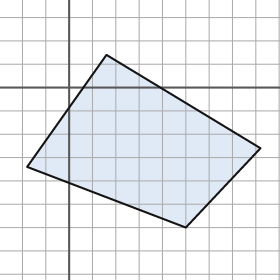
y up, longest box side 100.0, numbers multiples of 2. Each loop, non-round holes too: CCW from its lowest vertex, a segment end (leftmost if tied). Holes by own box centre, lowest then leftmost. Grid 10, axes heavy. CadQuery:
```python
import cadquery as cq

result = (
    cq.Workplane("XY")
    .moveTo(50.0, -60.0)
    .lineTo(82.0, -26.0)
    .lineTo(16.0, 14.0)
    .lineTo(-18.0, -34.0)
    .close()
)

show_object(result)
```